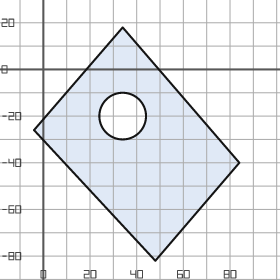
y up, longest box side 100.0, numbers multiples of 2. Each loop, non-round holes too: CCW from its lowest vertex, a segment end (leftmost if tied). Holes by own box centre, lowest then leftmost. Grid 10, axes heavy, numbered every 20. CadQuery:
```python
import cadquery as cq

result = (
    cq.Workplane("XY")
    .moveTo(48.0, -82.0)
    .lineTo(84.0, -40.0)
    .lineTo(34.0, 18.0)
    .lineTo(-4.0, -26.0)
    .close()
    .moveTo(34.0, -20.0)
    .circle(10.0)
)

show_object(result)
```